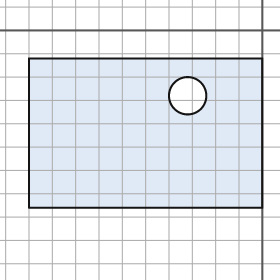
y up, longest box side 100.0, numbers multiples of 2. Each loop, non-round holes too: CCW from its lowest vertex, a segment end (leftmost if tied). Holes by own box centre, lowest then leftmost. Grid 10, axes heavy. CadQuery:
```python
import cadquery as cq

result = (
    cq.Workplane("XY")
    .moveTo(-100.0, -76.0)
    .lineTo(0.0, -76.0)
    .lineTo(0.0, -12.0)
    .lineTo(-100.0, -12.0)
    .close()
    .moveTo(-32.0, -28.0)
    .circle(8.0)
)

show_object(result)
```